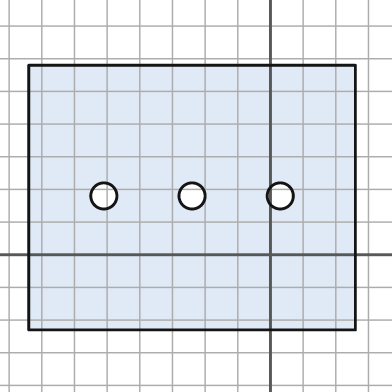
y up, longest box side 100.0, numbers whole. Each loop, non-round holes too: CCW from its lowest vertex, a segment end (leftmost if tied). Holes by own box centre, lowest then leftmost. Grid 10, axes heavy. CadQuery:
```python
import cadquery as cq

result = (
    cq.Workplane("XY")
    .moveTo(-74.0, -23.0)
    .lineTo(26.0, -23.0)
    .lineTo(26.0, 58.0)
    .lineTo(-74.0, 58.0)
    .close()
    .moveTo(-51.0, 18.0)
    .circle(4.0)
    .moveTo(-24.0, 18.0)
    .circle(4.0)
    .moveTo(3.0, 18.0)
    .circle(4.0)
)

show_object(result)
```